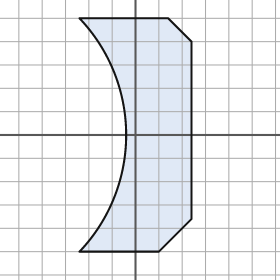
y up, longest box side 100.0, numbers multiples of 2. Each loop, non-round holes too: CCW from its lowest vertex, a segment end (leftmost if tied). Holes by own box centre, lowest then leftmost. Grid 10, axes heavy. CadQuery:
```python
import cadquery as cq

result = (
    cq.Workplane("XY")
    .moveTo(-24.0, -50.0)
    .lineTo(10.0, -50.0)
    .lineTo(24.0, -36.0)
    .lineTo(24.0, 40.0)
    .lineTo(14.0, 50.0)
    .lineTo(-24.0, 50.0)
    .threePointArc((-4.0, 0.0), (-24.0, -50.0))
    .close()
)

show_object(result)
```